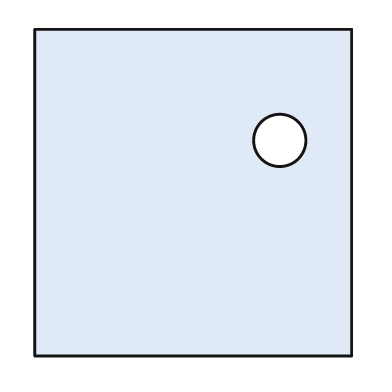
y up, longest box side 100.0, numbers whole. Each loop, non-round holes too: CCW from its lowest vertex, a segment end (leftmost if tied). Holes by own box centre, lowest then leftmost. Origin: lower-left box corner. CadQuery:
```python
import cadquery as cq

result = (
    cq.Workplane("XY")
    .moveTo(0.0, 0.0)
    .lineTo(97.0, 0.0)
    .lineTo(97.0, 100.0)
    .lineTo(0.0, 100.0)
    .close()
    .moveTo(75.0, 66.0)
    .circle(8.0)
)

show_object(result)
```